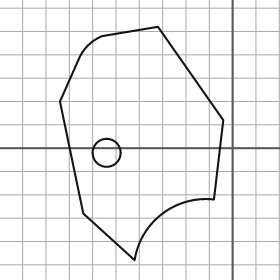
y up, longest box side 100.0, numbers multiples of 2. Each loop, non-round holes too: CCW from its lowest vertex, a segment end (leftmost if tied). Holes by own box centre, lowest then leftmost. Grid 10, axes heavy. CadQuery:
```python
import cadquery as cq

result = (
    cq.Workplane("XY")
    .moveTo(-42.0, -48.0)
    .threePointArc((-30.0, -28.0), (-8.0, -22.0))
    .lineTo(-4.0, 12.0)
    .lineTo(-32.0, 52.0)
    .lineTo(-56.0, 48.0)
    .threePointArc((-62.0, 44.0), (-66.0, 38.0))
    .lineTo(-74.0, 20.0)
    .lineTo(-64.0, -28.0)
    .close()
    .moveTo(-54.0, -2.0)
    .circle(6.0)
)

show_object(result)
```